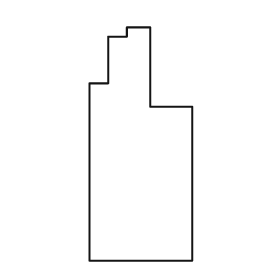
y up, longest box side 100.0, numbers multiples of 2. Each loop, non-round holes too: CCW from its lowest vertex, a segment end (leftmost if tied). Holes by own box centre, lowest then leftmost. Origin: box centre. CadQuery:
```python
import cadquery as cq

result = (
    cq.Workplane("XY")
    .moveTo(-22.0, -50.0)
    .lineTo(22.0, -50.0)
    .lineTo(22.0, 16.0)
    .lineTo(4.0, 16.0)
    .lineTo(4.0, 50.0)
    .lineTo(-6.0, 50.0)
    .lineTo(-6.0, 46.0)
    .lineTo(-14.0, 46.0)
    .lineTo(-14.0, 26.0)
    .lineTo(-22.0, 26.0)
    .close()
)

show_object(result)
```